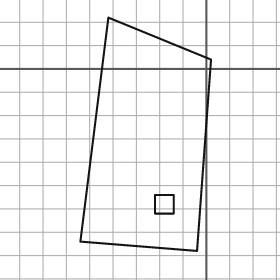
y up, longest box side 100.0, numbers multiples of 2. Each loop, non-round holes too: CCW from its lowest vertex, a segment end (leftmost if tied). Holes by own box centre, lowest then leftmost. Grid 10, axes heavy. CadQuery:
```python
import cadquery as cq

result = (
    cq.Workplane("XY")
    .moveTo(-4.0, -78.0)
    .lineTo(2.0, 4.0)
    .lineTo(-42.0, 22.0)
    .lineTo(-54.0, -74.0)
    .close()
    .moveTo(-22.0, -62.0)
    .lineTo(-14.0, -62.0)
    .lineTo(-14.0, -54.0)
    .lineTo(-22.0, -54.0)
    .close()
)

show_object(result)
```